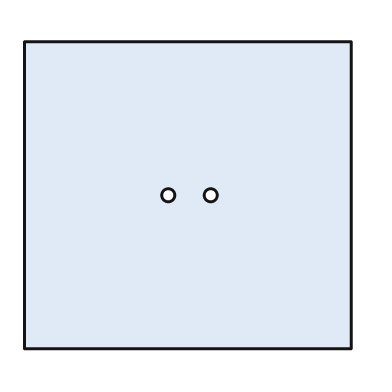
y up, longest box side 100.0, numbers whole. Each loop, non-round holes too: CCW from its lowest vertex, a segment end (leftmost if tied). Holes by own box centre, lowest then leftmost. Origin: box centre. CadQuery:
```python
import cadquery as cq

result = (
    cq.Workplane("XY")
    .moveTo(-50.0, -47.0)
    .lineTo(50.0, -47.0)
    .lineTo(50.0, 47.0)
    .lineTo(-50.0, 47.0)
    .close()
    .moveTo(-6.0, 0.0)
    .circle(2.0)
    .moveTo(7.0, 0.0)
    .circle(2.0)
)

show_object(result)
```